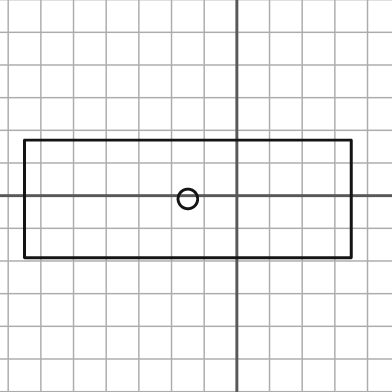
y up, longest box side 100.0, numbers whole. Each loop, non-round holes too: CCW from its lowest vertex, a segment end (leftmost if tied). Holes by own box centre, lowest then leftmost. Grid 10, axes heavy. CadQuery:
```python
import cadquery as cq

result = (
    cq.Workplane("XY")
    .moveTo(-65.0, -19.0)
    .lineTo(35.0, -19.0)
    .lineTo(35.0, 17.0)
    .lineTo(-65.0, 17.0)
    .close()
    .moveTo(-15.0, -1.0)
    .circle(3.0)
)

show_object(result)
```